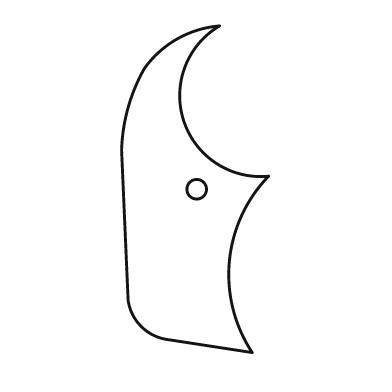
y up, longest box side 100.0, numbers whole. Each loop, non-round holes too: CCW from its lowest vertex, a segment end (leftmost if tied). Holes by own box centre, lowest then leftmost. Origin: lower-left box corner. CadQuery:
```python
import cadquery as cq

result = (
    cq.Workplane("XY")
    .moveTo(40.0, 0.0)
    .threePointArc((33.0, 28.0), (45.0, 54.0))
    .threePointArc((19.0, 71.0), (30.0, 100.0))
    .threePointArc((17.0, 96.0), (7.0, 87.0))
    .threePointArc((2.0, 75.0), (0.0, 62.0))
    .lineTo(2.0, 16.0)
    .threePointArc((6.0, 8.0), (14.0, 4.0))
    .close()
    .moveTo(23.0, 50.0)
    .circle(3.0)
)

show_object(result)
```